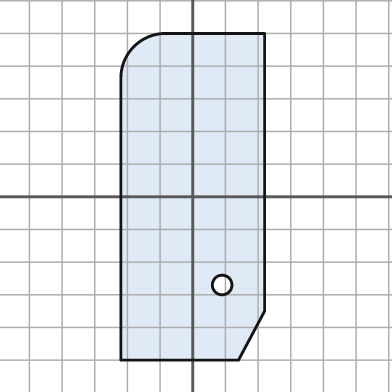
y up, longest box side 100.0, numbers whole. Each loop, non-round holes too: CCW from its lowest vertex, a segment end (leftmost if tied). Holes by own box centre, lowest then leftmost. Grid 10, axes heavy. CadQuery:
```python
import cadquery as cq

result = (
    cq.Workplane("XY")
    .moveTo(-22.0, -50.0)
    .lineTo(14.0, -50.0)
    .lineTo(22.0, -35.0)
    .lineTo(22.0, 50.0)
    .lineTo(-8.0, 50.0)
    .threePointArc((-18.0, 46.0), (-22.0, 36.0))
    .close()
    .moveTo(9.0, -27.0)
    .circle(3.0)
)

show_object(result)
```